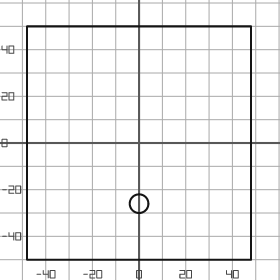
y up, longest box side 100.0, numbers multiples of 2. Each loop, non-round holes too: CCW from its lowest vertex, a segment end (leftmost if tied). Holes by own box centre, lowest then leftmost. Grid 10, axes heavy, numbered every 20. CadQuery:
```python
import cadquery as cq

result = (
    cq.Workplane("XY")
    .moveTo(-48.0, -50.0)
    .lineTo(48.0, -50.0)
    .lineTo(48.0, 50.0)
    .lineTo(-48.0, 50.0)
    .close()
    .moveTo(0.0, -26.0)
    .circle(4.0)
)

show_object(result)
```